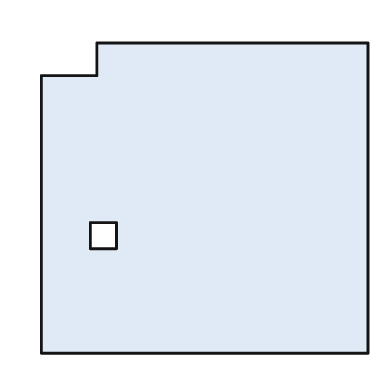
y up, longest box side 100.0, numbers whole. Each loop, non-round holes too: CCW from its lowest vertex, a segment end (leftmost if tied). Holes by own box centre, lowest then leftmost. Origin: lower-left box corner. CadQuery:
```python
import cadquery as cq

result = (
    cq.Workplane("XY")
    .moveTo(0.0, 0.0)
    .lineTo(100.0, 0.0)
    .lineTo(100.0, 95.0)
    .lineTo(17.0, 95.0)
    .lineTo(17.0, 85.0)
    .lineTo(0.0, 85.0)
    .close()
    .moveTo(15.0, 32.0)
    .lineTo(23.0, 32.0)
    .lineTo(23.0, 40.0)
    .lineTo(15.0, 40.0)
    .close()
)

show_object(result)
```